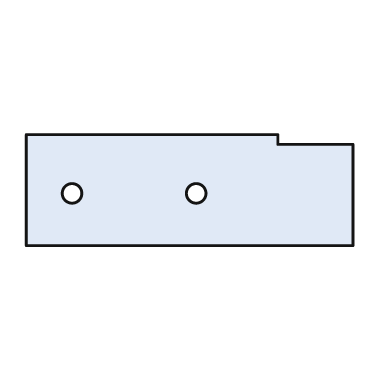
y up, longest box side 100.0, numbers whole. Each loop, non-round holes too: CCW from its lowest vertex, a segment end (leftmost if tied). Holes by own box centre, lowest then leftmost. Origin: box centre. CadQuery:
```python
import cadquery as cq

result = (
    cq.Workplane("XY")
    .moveTo(-50.0, -17.0)
    .lineTo(50.0, -17.0)
    .lineTo(50.0, 14.0)
    .lineTo(27.0, 14.0)
    .lineTo(27.0, 17.0)
    .lineTo(-50.0, 17.0)
    .close()
    .moveTo(-36.0, -1.0)
    .circle(3.0)
    .moveTo(2.0, -1.0)
    .circle(3.0)
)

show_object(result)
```